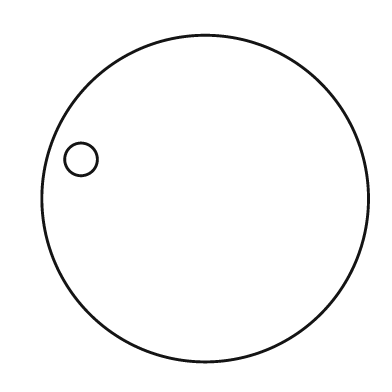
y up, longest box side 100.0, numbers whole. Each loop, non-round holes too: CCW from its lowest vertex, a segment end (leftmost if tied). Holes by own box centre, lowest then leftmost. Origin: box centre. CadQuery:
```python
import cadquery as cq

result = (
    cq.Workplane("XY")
    .moveTo(0.0, 0.0)
    .circle(50.0)
    .moveTo(-38.0, 12.0)
    .circle(5.0)
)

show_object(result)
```